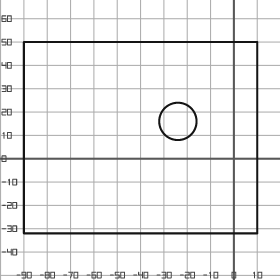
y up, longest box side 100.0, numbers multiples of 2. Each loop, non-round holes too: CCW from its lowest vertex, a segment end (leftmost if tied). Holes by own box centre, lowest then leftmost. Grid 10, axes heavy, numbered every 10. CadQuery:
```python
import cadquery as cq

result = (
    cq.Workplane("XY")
    .moveTo(-90.0, -32.0)
    .lineTo(10.0, -32.0)
    .lineTo(10.0, 50.0)
    .lineTo(-90.0, 50.0)
    .close()
    .moveTo(-24.0, 16.0)
    .circle(8.0)
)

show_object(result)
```